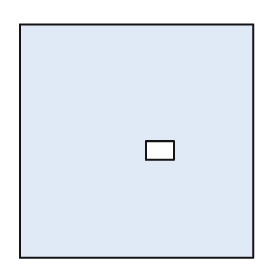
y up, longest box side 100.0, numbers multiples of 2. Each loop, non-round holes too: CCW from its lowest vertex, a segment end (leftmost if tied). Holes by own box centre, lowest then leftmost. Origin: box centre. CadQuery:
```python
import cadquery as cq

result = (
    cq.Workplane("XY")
    .moveTo(-50.0, -50.0)
    .lineTo(50.0, -50.0)
    .lineTo(50.0, 50.0)
    .lineTo(-50.0, 50.0)
    .close()
    .moveTo(4.0, -8.0)
    .lineTo(16.0, -8.0)
    .lineTo(16.0, 0.0)
    .lineTo(4.0, 0.0)
    .close()
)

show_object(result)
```